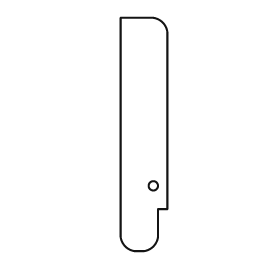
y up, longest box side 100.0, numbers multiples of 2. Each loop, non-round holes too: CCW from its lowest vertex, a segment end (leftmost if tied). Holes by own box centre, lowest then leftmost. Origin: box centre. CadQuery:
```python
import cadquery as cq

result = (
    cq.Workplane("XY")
    .moveTo(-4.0, -50.0)
    .lineTo(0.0, -50.0)
    .threePointArc((4.0, -48.0), (6.0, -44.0))
    .lineTo(6.0, -32.0)
    .lineTo(10.0, -32.0)
    .lineTo(10.0, 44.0)
    .threePointArc((8.0, 48.0), (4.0, 50.0))
    .lineTo(-10.0, 50.0)
    .lineTo(-10.0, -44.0)
    .threePointArc((-8.0, -48.0), (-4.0, -50.0))
    .close()
    .moveTo(4.0, -22.0)
    .circle(2.0)
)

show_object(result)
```